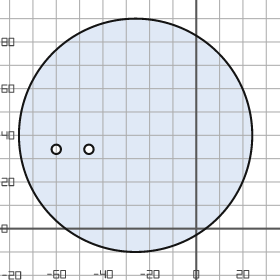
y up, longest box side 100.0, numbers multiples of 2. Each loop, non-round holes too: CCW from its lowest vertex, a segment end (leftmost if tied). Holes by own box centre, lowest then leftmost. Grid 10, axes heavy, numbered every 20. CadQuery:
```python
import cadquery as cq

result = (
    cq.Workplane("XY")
    .moveTo(-26.0, 40.0)
    .circle(50.0)
    .moveTo(-60.0, 34.0)
    .circle(2.0)
    .moveTo(-46.0, 34.0)
    .circle(2.0)
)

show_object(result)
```